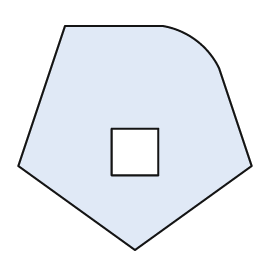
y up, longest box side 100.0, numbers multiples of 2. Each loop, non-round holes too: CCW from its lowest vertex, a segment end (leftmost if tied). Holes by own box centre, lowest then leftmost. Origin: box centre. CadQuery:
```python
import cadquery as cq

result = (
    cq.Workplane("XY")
    .moveTo(0.0, -48.0)
    .lineTo(50.0, -12.0)
    .lineTo(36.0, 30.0)
    .threePointArc((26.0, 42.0), (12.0, 48.0))
    .lineTo(-30.0, 48.0)
    .lineTo(-50.0, -12.0)
    .close()
    .moveTo(-10.0, -16.0)
    .lineTo(10.0, -16.0)
    .lineTo(10.0, 4.0)
    .lineTo(-10.0, 4.0)
    .close()
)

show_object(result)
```